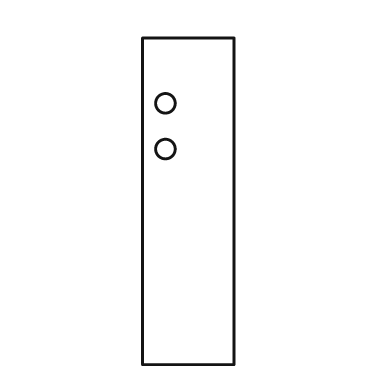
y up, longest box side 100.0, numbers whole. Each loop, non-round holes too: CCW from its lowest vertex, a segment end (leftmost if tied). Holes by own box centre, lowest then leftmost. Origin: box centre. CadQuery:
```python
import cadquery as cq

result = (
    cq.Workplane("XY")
    .moveTo(-14.0, -50.0)
    .lineTo(14.0, -50.0)
    .lineTo(14.0, 50.0)
    .lineTo(-14.0, 50.0)
    .close()
    .moveTo(-7.0, 16.0)
    .circle(3.0)
    .moveTo(-7.0, 30.0)
    .circle(3.0)
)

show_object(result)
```